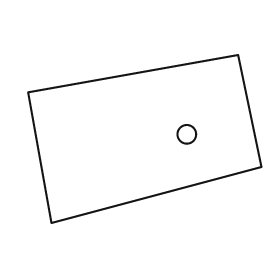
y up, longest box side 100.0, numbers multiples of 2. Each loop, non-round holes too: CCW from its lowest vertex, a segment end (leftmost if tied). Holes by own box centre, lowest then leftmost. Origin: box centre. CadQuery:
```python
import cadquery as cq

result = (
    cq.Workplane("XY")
    .moveTo(-40.0, -36.0)
    .lineTo(50.0, -12.0)
    .lineTo(40.0, 36.0)
    .lineTo(-50.0, 20.0)
    .close()
    .moveTo(18.0, 2.0)
    .circle(4.0)
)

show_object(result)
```